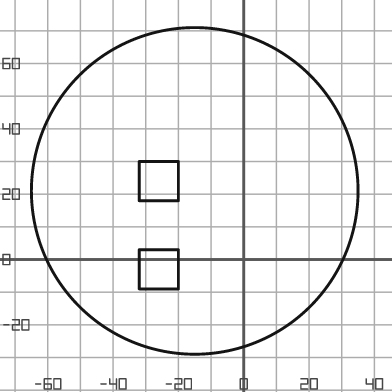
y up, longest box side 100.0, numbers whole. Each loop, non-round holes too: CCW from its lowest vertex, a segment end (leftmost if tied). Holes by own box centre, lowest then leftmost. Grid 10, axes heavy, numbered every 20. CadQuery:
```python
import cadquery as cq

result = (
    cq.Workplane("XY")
    .moveTo(-15.0, 21.0)
    .circle(50.0)
    .moveTo(-32.0, -9.0)
    .lineTo(-20.0, -9.0)
    .lineTo(-20.0, 3.0)
    .lineTo(-32.0, 3.0)
    .close()
    .moveTo(-32.0, 18.0)
    .lineTo(-20.0, 18.0)
    .lineTo(-20.0, 30.0)
    .lineTo(-32.0, 30.0)
    .close()
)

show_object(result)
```